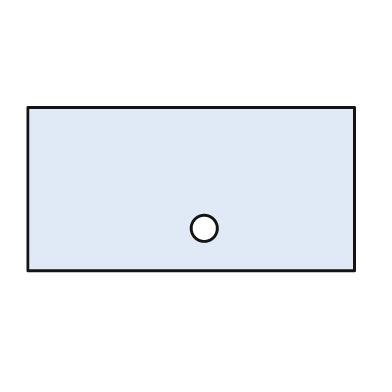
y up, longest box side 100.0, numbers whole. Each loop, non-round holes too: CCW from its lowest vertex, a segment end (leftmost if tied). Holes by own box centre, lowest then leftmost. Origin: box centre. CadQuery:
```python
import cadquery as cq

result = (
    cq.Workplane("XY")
    .moveTo(-50.0, -25.0)
    .lineTo(50.0, -25.0)
    .lineTo(50.0, 25.0)
    .lineTo(-50.0, 25.0)
    .close()
    .moveTo(4.0, -12.0)
    .circle(4.0)
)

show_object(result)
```